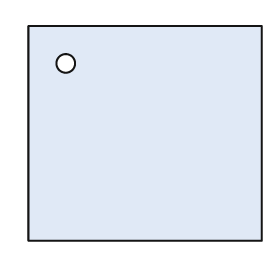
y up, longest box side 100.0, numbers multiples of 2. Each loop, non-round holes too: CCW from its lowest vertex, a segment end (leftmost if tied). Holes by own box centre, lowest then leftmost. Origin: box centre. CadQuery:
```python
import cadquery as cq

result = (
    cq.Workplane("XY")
    .moveTo(-50.0, -46.0)
    .lineTo(50.0, -46.0)
    .lineTo(50.0, 46.0)
    .lineTo(-50.0, 46.0)
    .close()
    .moveTo(-34.0, 30.0)
    .circle(4.0)
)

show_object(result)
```